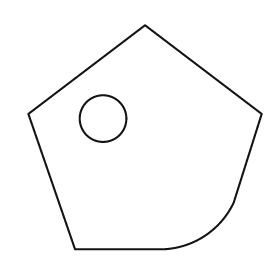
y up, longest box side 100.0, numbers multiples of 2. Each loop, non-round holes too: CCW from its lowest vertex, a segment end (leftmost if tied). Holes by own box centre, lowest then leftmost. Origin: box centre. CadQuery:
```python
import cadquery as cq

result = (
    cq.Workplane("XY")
    .moveTo(-30.0, -48.0)
    .lineTo(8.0, -48.0)
    .threePointArc((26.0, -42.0), (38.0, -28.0))
    .lineTo(50.0, 10.0)
    .lineTo(0.0, 48.0)
    .lineTo(-50.0, 10.0)
    .close()
    .moveTo(-18.0, 8.0)
    .circle(10.0)
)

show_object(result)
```